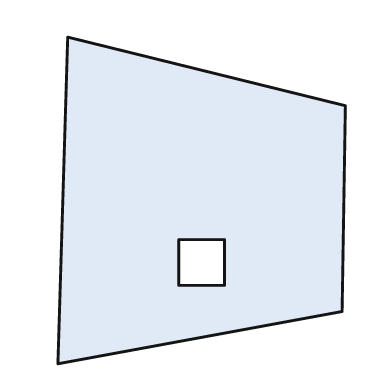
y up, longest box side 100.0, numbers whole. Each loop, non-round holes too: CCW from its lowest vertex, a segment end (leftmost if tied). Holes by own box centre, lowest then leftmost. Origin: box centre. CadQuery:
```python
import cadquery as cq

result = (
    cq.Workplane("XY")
    .moveTo(-44.0, -50.0)
    .lineTo(43.0, -34.0)
    .lineTo(44.0, 29.0)
    .lineTo(-41.0, 50.0)
    .close()
    .moveTo(-7.0, -26.0)
    .lineTo(7.0, -26.0)
    .lineTo(7.0, -12.0)
    .lineTo(-7.0, -12.0)
    .close()
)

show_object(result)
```